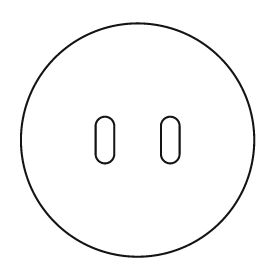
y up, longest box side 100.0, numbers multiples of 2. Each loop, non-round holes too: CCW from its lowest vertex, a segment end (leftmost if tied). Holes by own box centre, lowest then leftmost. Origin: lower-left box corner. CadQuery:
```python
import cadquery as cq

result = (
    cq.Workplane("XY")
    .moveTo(50.0, 50.0)
    .circle(50.0)
    .moveTo(32.0, 44.0)
    .threePointArc((36.0, 40.0), (40.0, 44.0))
    .lineTo(40.0, 56.0)
    .threePointArc((36.0, 60.0), (32.0, 56.0))
    .close()
    .moveTo(60.0, 44.0)
    .threePointArc((64.0, 40.0), (68.0, 44.0))
    .lineTo(68.0, 56.0)
    .threePointArc((64.0, 60.0), (60.0, 56.0))
    .close()
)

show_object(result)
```